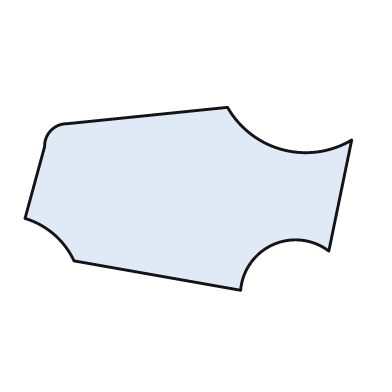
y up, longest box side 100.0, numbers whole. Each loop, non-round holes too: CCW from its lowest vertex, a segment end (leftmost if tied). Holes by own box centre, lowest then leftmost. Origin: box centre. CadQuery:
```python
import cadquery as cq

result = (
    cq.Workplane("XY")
    .moveTo(16.0, -28.0)
    .threePointArc((26.0, -14.0), (43.0, -16.0))
    .lineTo(50.0, 18.0)
    .threePointArc((29.0, 15.0), (12.0, 28.0))
    .lineTo(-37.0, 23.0)
    .threePointArc((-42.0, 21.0), (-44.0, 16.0))
    .lineTo(-50.0, -6.0)
    .threePointArc((-41.0, -11.0), (-35.0, -19.0))
    .close()
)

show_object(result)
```